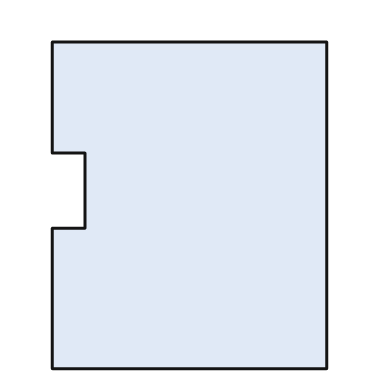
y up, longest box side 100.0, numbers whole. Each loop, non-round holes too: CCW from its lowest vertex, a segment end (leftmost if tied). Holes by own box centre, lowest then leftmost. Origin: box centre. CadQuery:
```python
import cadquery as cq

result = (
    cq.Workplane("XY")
    .moveTo(-42.0, -50.0)
    .lineTo(42.0, -50.0)
    .lineTo(42.0, 50.0)
    .lineTo(-42.0, 50.0)
    .lineTo(-42.0, 16.0)
    .lineTo(-32.0, 16.0)
    .lineTo(-32.0, -7.0)
    .lineTo(-42.0, -7.0)
    .close()
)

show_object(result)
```